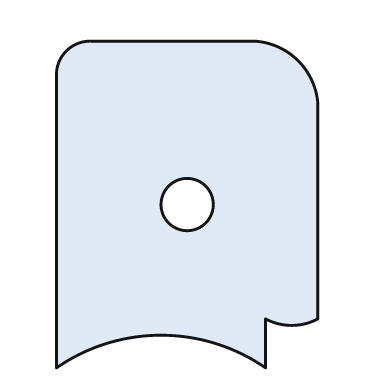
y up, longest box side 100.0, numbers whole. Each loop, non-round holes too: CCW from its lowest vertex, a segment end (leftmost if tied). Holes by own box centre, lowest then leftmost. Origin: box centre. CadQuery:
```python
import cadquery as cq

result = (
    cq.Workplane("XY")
    .moveTo(-40.0, -50.0)
    .threePointArc((-8.0, -40.0), (24.0, -50.0))
    .lineTo(24.0, -35.0)
    .threePointArc((32.0, -37.0), (40.0, -35.0))
    .lineTo(40.0, 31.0)
    .threePointArc((34.0, 44.0), (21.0, 50.0))
    .lineTo(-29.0, 50.0)
    .threePointArc((-37.0, 47.0), (-40.0, 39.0))
    .close()
    .moveTo(0.0, 0.0)
    .circle(8.0)
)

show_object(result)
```